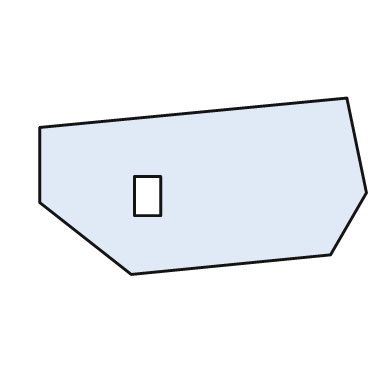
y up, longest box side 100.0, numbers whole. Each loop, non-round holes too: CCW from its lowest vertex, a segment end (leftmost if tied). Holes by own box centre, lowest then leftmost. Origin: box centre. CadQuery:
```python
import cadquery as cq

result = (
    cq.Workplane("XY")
    .moveTo(-22.0, -27.0)
    .lineTo(39.0, -21.0)
    .lineTo(50.0, -2.0)
    .lineTo(44.0, 27.0)
    .lineTo(-50.0, 18.0)
    .lineTo(-50.0, -5.0)
    .close()
    .moveTo(-21.0, -9.0)
    .lineTo(-13.0, -9.0)
    .lineTo(-13.0, 3.0)
    .lineTo(-21.0, 3.0)
    .close()
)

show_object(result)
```